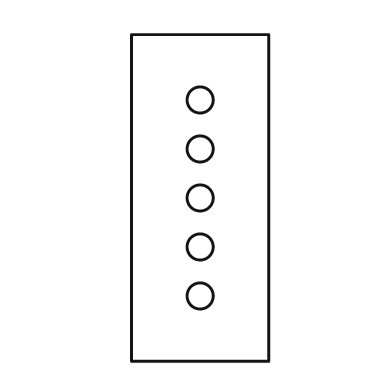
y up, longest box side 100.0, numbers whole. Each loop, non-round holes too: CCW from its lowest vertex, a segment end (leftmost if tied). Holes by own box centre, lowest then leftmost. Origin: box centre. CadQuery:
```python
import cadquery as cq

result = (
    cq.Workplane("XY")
    .moveTo(-21.0, -50.0)
    .lineTo(21.0, -50.0)
    .lineTo(21.0, 50.0)
    .lineTo(-21.0, 50.0)
    .close()
    .moveTo(0.0, -30.0)
    .circle(4.0)
    .moveTo(0.0, -15.0)
    .circle(4.0)
    .moveTo(0.0, 0.0)
    .circle(4.0)
    .moveTo(0.0, 15.0)
    .circle(4.0)
    .moveTo(0.0, 30.0)
    .circle(4.0)
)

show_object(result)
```